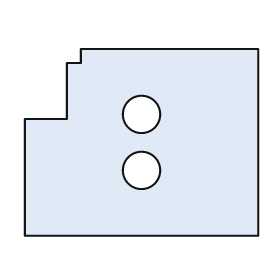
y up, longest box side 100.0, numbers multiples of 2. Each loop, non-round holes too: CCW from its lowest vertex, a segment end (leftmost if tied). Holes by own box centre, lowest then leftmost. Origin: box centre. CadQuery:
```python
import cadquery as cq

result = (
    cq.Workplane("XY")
    .moveTo(-50.0, -40.0)
    .lineTo(50.0, -40.0)
    .lineTo(50.0, 40.0)
    .lineTo(-26.0, 40.0)
    .lineTo(-26.0, 34.0)
    .lineTo(-32.0, 34.0)
    .lineTo(-32.0, 10.0)
    .lineTo(-50.0, 10.0)
    .close()
    .moveTo(0.0, -12.0)
    .circle(8.0)
    .moveTo(0.0, 12.0)
    .circle(8.0)
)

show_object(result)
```